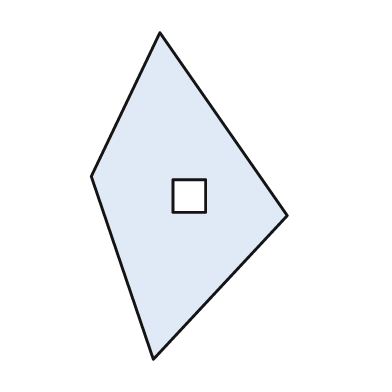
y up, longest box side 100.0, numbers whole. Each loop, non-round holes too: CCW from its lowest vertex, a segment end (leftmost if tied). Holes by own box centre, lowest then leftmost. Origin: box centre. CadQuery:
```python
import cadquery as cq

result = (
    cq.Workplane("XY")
    .moveTo(-11.0, -50.0)
    .lineTo(30.0, -6.0)
    .lineTo(-9.0, 50.0)
    .lineTo(-30.0, 6.0)
    .close()
    .moveTo(-5.0, -5.0)
    .lineTo(5.0, -5.0)
    .lineTo(5.0, 5.0)
    .lineTo(-5.0, 5.0)
    .close()
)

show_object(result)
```